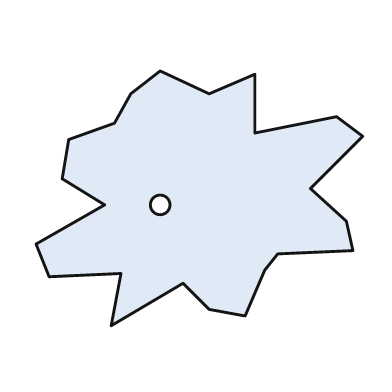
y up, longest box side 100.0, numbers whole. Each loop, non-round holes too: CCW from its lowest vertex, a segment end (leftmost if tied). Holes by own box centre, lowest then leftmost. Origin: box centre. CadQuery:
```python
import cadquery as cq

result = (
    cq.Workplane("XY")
    .moveTo(-27.0, -39.0)
    .lineTo(-5.0, -26.0)
    .lineTo(3.0, -34.0)
    .lineTo(14.0, -36.0)
    .lineTo(20.0, -22.0)
    .lineTo(24.0, -17.0)
    .lineTo(47.0, -16.0)
    .lineTo(45.0, -7.0)
    .lineTo(34.0, 3.0)
    .lineTo(50.0, 19.0)
    .lineTo(42.0, 25.0)
    .lineTo(17.0, 20.0)
    .lineTo(17.0, 38.0)
    .lineTo(3.0, 32.0)
    .lineTo(-12.0, 39.0)
    .lineTo(-21.0, 32.0)
    .lineTo(-26.0, 23.0)
    .lineTo(-40.0, 18.0)
    .lineTo(-42.0, 6.0)
    .lineTo(-29.0, -2.0)
    .lineTo(-50.0, -14.0)
    .lineTo(-46.0, -24.0)
    .lineTo(-24.0, -23.0)
    .close()
    .moveTo(-12.0, -2.0)
    .circle(3.0)
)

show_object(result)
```